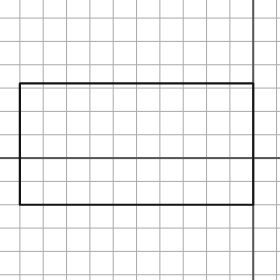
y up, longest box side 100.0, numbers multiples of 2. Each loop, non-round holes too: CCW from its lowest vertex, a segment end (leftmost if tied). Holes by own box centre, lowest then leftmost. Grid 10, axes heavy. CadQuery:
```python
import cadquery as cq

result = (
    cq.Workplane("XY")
    .moveTo(-100.0, -20.0)
    .lineTo(0.0, -20.0)
    .lineTo(0.0, 32.0)
    .lineTo(-100.0, 32.0)
    .close()
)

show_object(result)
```